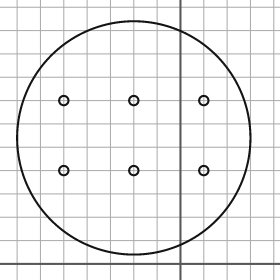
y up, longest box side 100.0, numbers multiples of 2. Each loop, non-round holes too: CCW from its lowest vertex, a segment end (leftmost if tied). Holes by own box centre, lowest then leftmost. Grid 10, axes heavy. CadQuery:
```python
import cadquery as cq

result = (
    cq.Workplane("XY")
    .moveTo(-20.0, 54.0)
    .circle(50.0)
    .moveTo(-50.0, 40.0)
    .circle(2.0)
    .moveTo(-20.0, 40.0)
    .circle(2.0)
    .moveTo(10.0, 40.0)
    .circle(2.0)
    .moveTo(-50.0, 70.0)
    .circle(2.0)
    .moveTo(-20.0, 70.0)
    .circle(2.0)
    .moveTo(10.0, 70.0)
    .circle(2.0)
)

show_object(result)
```